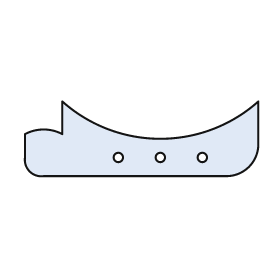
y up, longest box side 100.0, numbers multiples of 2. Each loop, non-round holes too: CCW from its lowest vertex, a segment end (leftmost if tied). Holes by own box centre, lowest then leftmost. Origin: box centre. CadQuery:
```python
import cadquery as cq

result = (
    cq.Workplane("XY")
    .moveTo(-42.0, -16.0)
    .lineTo(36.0, -16.0)
    .threePointArc((46.0, -12.0), (50.0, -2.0))
    .lineTo(50.0, 16.0)
    .threePointArc((8.0, 0.0), (-34.0, 16.0))
    .lineTo(-34.0, 2.0)
    .threePointArc((-42.0, 4.0), (-50.0, 2.0))
    .lineTo(-50.0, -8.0)
    .threePointArc((-48.0, -14.0), (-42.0, -16.0))
    .close()
    .moveTo(-10.0, -8.0)
    .circle(2.0)
    .moveTo(8.0, -8.0)
    .circle(2.0)
    .moveTo(26.0, -8.0)
    .circle(2.0)
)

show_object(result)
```